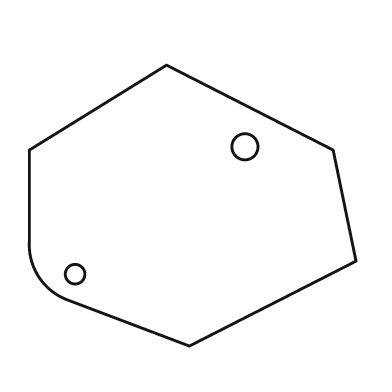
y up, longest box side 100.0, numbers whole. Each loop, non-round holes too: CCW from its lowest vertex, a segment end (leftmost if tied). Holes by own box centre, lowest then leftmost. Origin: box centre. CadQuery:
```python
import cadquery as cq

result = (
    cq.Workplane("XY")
    .moveTo(-1.0, -43.0)
    .lineTo(50.0, -17.0)
    .lineTo(43.0, 17.0)
    .lineTo(-8.0, 43.0)
    .lineTo(-50.0, 17.0)
    .lineTo(-50.0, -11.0)
    .threePointArc((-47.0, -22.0), (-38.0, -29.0))
    .close()
    .moveTo(-36.0, -21.0)
    .circle(3.0)
    .moveTo(16.0, 18.0)
    .circle(4.0)
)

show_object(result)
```